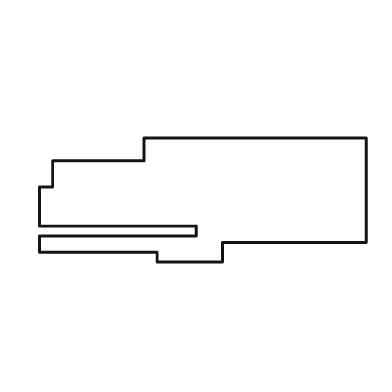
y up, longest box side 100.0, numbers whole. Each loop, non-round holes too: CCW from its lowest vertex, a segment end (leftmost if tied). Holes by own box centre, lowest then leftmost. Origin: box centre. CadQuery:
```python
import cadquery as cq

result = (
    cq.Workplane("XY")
    .moveTo(-14.0, -19.0)
    .lineTo(6.0, -19.0)
    .lineTo(6.0, -13.0)
    .lineTo(50.0, -13.0)
    .lineTo(50.0, 19.0)
    .lineTo(-18.0, 19.0)
    .lineTo(-18.0, 12.0)
    .lineTo(-46.0, 12.0)
    .lineTo(-46.0, 4.0)
    .lineTo(-50.0, 4.0)
    .lineTo(-50.0, -8.0)
    .lineTo(-2.0, -8.0)
    .lineTo(-2.0, -11.0)
    .lineTo(-50.0, -11.0)
    .lineTo(-50.0, -16.0)
    .lineTo(-14.0, -16.0)
    .close()
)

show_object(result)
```